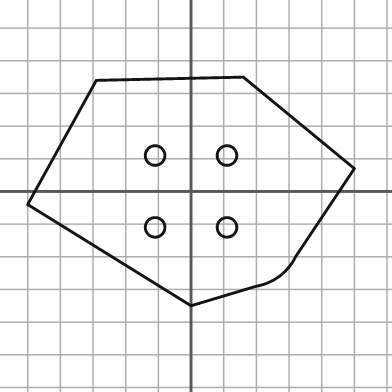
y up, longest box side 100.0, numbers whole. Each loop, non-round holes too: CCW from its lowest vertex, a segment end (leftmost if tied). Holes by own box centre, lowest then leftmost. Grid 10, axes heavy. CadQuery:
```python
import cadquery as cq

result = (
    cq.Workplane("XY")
    .moveTo(0.0, -35.0)
    .lineTo(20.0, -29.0)
    .threePointArc((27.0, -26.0), (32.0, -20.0))
    .lineTo(50.0, 7.0)
    .lineTo(16.0, 35.0)
    .lineTo(-29.0, 34.0)
    .lineTo(-50.0, -4.0)
    .close()
    .moveTo(-11.0, -11.0)
    .circle(3.0)
    .moveTo(11.0, -11.0)
    .circle(3.0)
    .moveTo(-11.0, 11.0)
    .circle(3.0)
    .moveTo(11.0, 11.0)
    .circle(3.0)
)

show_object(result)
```